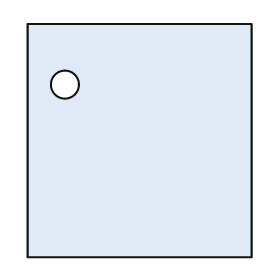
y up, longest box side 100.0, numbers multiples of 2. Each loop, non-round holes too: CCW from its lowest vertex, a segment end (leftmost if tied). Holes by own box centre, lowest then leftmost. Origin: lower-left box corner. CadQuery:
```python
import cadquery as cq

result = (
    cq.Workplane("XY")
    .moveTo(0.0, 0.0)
    .lineTo(96.0, 0.0)
    .lineTo(96.0, 100.0)
    .lineTo(0.0, 100.0)
    .close()
    .moveTo(16.0, 74.0)
    .circle(6.0)
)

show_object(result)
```